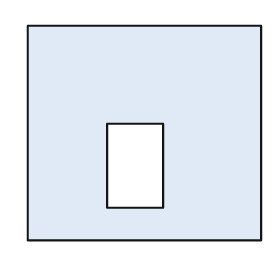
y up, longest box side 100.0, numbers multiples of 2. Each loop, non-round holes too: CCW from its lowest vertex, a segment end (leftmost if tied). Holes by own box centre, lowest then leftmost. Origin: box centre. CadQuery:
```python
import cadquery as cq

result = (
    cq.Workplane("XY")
    .moveTo(-50.0, -46.0)
    .lineTo(50.0, -46.0)
    .lineTo(50.0, 46.0)
    .lineTo(-50.0, 46.0)
    .close()
    .moveTo(-16.0, -32.0)
    .lineTo(8.0, -32.0)
    .lineTo(8.0, 4.0)
    .lineTo(-16.0, 4.0)
    .close()
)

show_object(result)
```